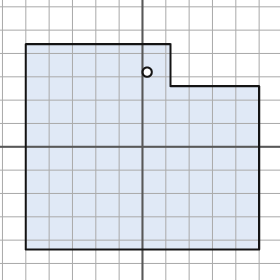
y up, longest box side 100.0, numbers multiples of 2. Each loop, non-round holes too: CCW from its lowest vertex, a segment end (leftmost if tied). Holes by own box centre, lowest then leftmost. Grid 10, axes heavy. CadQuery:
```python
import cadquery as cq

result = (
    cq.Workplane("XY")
    .moveTo(-50.0, -44.0)
    .lineTo(50.0, -44.0)
    .lineTo(50.0, 26.0)
    .lineTo(12.0, 26.0)
    .lineTo(12.0, 44.0)
    .lineTo(-50.0, 44.0)
    .close()
    .moveTo(2.0, 32.0)
    .circle(2.0)
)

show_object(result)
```